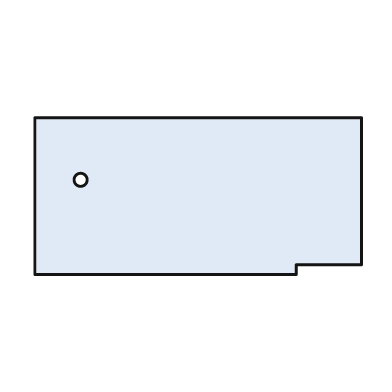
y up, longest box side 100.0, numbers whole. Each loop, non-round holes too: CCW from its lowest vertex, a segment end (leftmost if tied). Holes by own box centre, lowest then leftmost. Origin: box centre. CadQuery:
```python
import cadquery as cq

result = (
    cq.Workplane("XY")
    .moveTo(-50.0, -24.0)
    .lineTo(30.0, -24.0)
    .lineTo(30.0, -21.0)
    .lineTo(50.0, -21.0)
    .lineTo(50.0, 24.0)
    .lineTo(-50.0, 24.0)
    .close()
    .moveTo(-36.0, 5.0)
    .circle(2.0)
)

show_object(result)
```